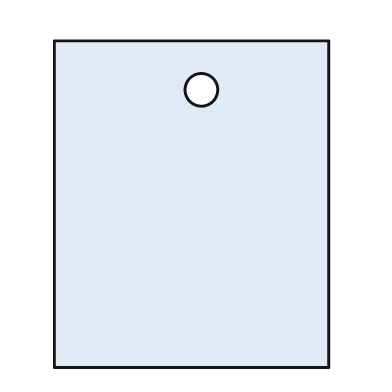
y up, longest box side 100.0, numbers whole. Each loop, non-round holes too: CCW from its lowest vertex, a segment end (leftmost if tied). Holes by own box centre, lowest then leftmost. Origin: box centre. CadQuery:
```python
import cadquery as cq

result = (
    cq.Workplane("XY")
    .moveTo(-42.0, -50.0)
    .lineTo(42.0, -50.0)
    .lineTo(42.0, 50.0)
    .lineTo(-42.0, 50.0)
    .close()
    .moveTo(3.0, 35.0)
    .circle(5.0)
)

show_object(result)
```